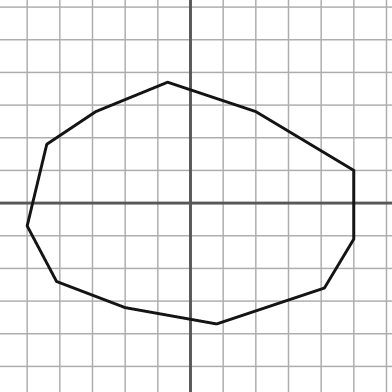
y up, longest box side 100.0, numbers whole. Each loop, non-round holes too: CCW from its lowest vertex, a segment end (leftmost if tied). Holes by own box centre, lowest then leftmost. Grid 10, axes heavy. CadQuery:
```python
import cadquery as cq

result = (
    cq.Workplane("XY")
    .moveTo(8.0, -37.0)
    .lineTo(41.0, -26.0)
    .lineTo(50.0, -11.0)
    .lineTo(50.0, 10.0)
    .lineTo(20.0, 28.0)
    .lineTo(-7.0, 37.0)
    .lineTo(-29.0, 28.0)
    .lineTo(-44.0, 18.0)
    .lineTo(-50.0, -7.0)
    .lineTo(-41.0, -24.0)
    .lineTo(-20.0, -32.0)
    .close()
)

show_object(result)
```